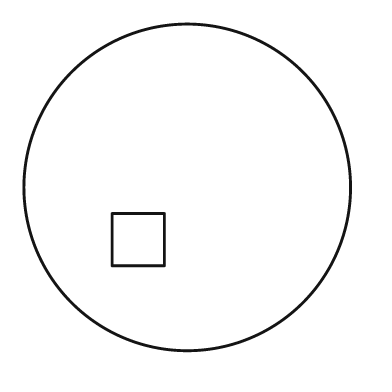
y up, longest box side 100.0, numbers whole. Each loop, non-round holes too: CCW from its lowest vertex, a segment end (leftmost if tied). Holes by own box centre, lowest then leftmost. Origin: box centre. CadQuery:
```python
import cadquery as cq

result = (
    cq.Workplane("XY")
    .moveTo(0.0, 0.0)
    .circle(50.0)
    .moveTo(-23.0, -24.0)
    .lineTo(-7.0, -24.0)
    .lineTo(-7.0, -8.0)
    .lineTo(-23.0, -8.0)
    .close()
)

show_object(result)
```